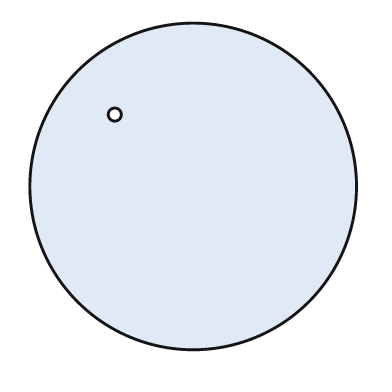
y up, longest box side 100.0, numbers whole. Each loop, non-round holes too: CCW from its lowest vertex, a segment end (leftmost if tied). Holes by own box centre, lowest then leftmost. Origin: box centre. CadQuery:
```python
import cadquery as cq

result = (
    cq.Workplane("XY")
    .moveTo(0.0, 0.0)
    .circle(50.0)
    .moveTo(-24.0, 22.0)
    .circle(2.0)
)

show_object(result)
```